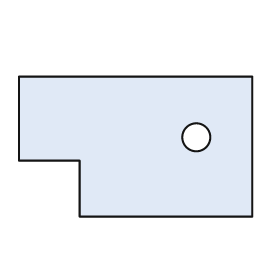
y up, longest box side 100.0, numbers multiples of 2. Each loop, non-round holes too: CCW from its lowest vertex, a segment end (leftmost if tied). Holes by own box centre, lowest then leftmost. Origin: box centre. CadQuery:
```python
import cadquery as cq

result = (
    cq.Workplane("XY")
    .moveTo(-24.0, -30.0)
    .lineTo(50.0, -30.0)
    .lineTo(50.0, 30.0)
    .lineTo(-50.0, 30.0)
    .lineTo(-50.0, -6.0)
    .lineTo(-24.0, -6.0)
    .close()
    .moveTo(26.0, 4.0)
    .circle(6.0)
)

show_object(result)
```